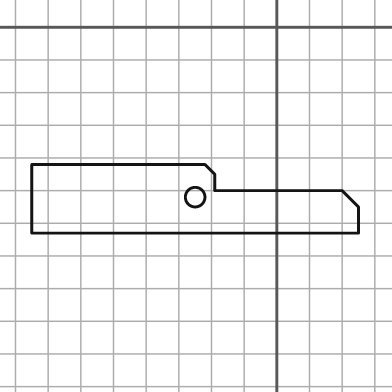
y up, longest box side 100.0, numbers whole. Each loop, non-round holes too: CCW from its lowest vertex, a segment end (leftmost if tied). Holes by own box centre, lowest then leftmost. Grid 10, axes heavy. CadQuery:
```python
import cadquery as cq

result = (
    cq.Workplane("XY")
    .moveTo(-75.0, -63.0)
    .lineTo(25.0, -63.0)
    .lineTo(25.0, -55.0)
    .lineTo(20.0, -50.0)
    .lineTo(-19.0, -50.0)
    .lineTo(-19.0, -45.0)
    .lineTo(-22.0, -42.0)
    .lineTo(-75.0, -42.0)
    .close()
    .moveTo(-25.0, -52.0)
    .circle(3.0)
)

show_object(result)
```